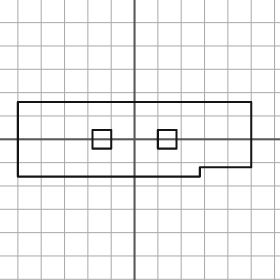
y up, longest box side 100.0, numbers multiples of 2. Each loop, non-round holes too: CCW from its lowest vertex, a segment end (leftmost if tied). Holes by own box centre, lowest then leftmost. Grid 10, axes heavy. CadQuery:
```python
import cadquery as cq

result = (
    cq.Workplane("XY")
    .moveTo(-50.0, -16.0)
    .lineTo(28.0, -16.0)
    .lineTo(28.0, -12.0)
    .lineTo(50.0, -12.0)
    .lineTo(50.0, 16.0)
    .lineTo(-50.0, 16.0)
    .close()
    .moveTo(-18.0, -4.0)
    .lineTo(-10.0, -4.0)
    .lineTo(-10.0, 4.0)
    .lineTo(-18.0, 4.0)
    .close()
    .moveTo(10.0, -4.0)
    .lineTo(18.0, -4.0)
    .lineTo(18.0, 4.0)
    .lineTo(10.0, 4.0)
    .close()
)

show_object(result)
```